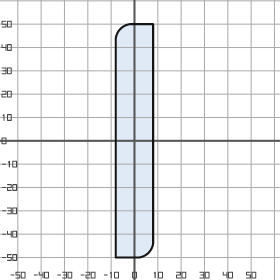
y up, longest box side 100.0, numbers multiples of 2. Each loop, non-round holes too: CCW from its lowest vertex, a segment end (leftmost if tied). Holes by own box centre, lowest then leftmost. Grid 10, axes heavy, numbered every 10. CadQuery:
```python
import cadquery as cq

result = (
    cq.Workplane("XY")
    .moveTo(-8.0, -50.0)
    .lineTo(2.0, -50.0)
    .threePointArc((6.0, -48.0), (8.0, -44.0))
    .lineTo(8.0, 50.0)
    .lineTo(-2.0, 50.0)
    .threePointArc((-6.0, 48.0), (-8.0, 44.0))
    .close()
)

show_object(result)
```